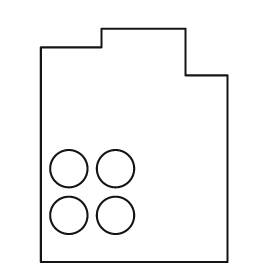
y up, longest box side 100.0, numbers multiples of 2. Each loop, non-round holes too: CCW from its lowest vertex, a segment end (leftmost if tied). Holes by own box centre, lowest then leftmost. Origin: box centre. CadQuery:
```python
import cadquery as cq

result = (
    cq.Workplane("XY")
    .moveTo(-40.0, -50.0)
    .lineTo(40.0, -50.0)
    .lineTo(40.0, 30.0)
    .lineTo(22.0, 30.0)
    .lineTo(22.0, 50.0)
    .lineTo(-14.0, 50.0)
    .lineTo(-14.0, 42.0)
    .lineTo(-40.0, 42.0)
    .close()
    .moveTo(-28.0, -30.0)
    .circle(8.0)
    .moveTo(-8.0, -30.0)
    .circle(8.0)
    .moveTo(-28.0, -10.0)
    .circle(8.0)
    .moveTo(-8.0, -10.0)
    .circle(8.0)
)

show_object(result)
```